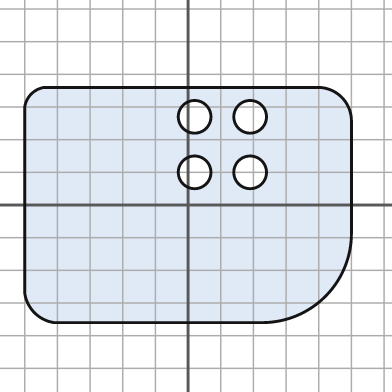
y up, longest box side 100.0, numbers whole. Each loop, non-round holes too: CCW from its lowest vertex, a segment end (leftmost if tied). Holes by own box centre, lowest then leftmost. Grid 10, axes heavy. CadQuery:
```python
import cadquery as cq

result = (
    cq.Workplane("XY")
    .moveTo(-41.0, -36.0)
    .lineTo(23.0, -36.0)
    .threePointArc((42.0, -28.0), (50.0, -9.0))
    .lineTo(50.0, 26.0)
    .threePointArc((47.0, 33.0), (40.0, 36.0))
    .lineTo(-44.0, 36.0)
    .threePointArc((-48.0, 34.0), (-50.0, 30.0))
    .lineTo(-50.0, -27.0)
    .threePointArc((-47.0, -33.0), (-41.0, -36.0))
    .close()
    .moveTo(2.0, 10.0)
    .circle(5.0)
    .moveTo(19.0, 10.0)
    .circle(5.0)
    .moveTo(2.0, 27.0)
    .circle(5.0)
    .moveTo(19.0, 27.0)
    .circle(5.0)
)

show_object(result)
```